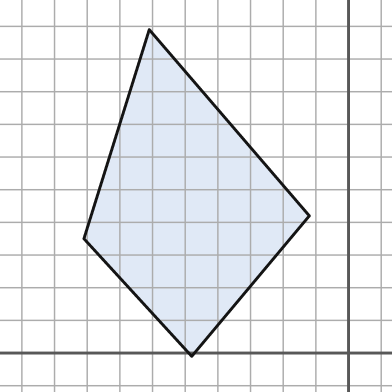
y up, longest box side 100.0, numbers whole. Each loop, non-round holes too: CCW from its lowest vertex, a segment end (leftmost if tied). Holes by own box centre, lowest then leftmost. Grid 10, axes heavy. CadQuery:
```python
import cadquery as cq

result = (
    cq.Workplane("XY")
    .moveTo(-48.0, -1.0)
    .lineTo(-12.0, 42.0)
    .lineTo(-61.0, 99.0)
    .lineTo(-81.0, 35.0)
    .close()
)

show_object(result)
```